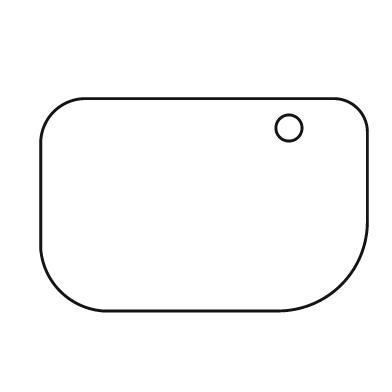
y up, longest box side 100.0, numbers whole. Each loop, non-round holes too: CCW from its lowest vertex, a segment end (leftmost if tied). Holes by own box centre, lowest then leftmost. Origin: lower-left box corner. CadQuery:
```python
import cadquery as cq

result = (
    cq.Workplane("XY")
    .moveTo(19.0, 0.0)
    .lineTo(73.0, 0.0)
    .threePointArc((92.0, 8.0), (100.0, 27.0))
    .lineTo(100.0, 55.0)
    .threePointArc((97.0, 62.0), (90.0, 65.0))
    .lineTo(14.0, 65.0)
    .threePointArc((4.0, 61.0), (0.0, 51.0))
    .lineTo(0.0, 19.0)
    .threePointArc((6.0, 6.0), (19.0, 0.0))
    .close()
    .moveTo(76.0, 56.0)
    .circle(4.0)
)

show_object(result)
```